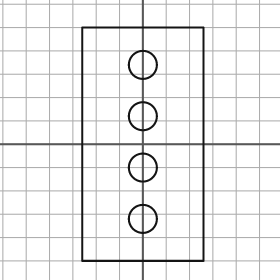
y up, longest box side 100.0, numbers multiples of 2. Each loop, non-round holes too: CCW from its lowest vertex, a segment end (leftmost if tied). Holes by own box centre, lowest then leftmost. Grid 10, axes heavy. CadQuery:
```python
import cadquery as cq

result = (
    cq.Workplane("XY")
    .moveTo(-26.0, -50.0)
    .lineTo(26.0, -50.0)
    .lineTo(26.0, 50.0)
    .lineTo(-26.0, 50.0)
    .close()
    .moveTo(0.0, -32.0)
    .circle(6.0)
    .moveTo(0.0, -10.0)
    .circle(6.0)
    .moveTo(0.0, 12.0)
    .circle(6.0)
    .moveTo(0.0, 34.0)
    .circle(6.0)
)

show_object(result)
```